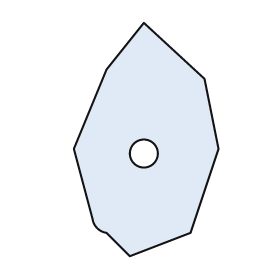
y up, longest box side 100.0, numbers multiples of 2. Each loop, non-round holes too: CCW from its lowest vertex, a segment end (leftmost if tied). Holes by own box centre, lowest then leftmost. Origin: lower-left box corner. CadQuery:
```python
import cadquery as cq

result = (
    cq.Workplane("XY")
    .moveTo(24.0, 0.0)
    .lineTo(50.0, 10.0)
    .lineTo(62.0, 46.0)
    .lineTo(56.0, 76.0)
    .lineTo(30.0, 100.0)
    .lineTo(14.0, 80.0)
    .lineTo(0.0, 46.0)
    .lineTo(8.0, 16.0)
    .threePointArc((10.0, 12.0), (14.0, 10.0))
    .close()
    .moveTo(30.0, 44.0)
    .circle(6.0)
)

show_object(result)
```